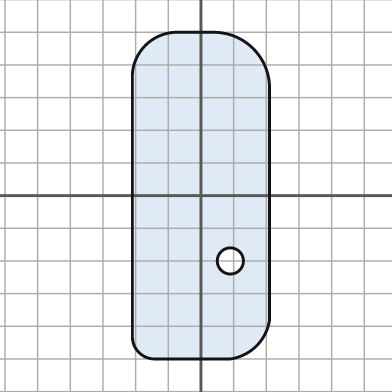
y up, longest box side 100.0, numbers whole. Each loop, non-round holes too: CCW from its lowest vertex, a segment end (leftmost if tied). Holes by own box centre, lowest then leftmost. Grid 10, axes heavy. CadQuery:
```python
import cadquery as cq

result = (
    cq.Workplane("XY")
    .moveTo(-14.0, -50.0)
    .lineTo(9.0, -50.0)
    .threePointArc((17.0, -46.0), (21.0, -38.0))
    .lineTo(21.0, 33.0)
    .threePointArc((16.0, 45.0), (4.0, 50.0))
    .lineTo(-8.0, 50.0)
    .threePointArc((-17.0, 46.0), (-21.0, 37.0))
    .lineTo(-21.0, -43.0)
    .threePointArc((-19.0, -48.0), (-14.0, -50.0))
    .close()
    .moveTo(9.0, -20.0)
    .circle(4.0)
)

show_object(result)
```